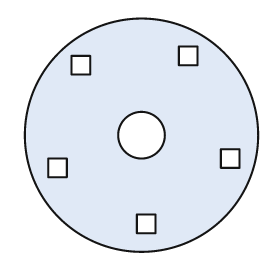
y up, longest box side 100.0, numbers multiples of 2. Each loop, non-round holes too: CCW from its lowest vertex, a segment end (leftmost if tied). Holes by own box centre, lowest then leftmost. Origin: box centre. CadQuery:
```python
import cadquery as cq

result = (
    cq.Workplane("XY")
    .moveTo(0.0, 0.0)
    .circle(50.0)
    .moveTo(-2.0, -42.0)
    .lineTo(6.0, -42.0)
    .lineTo(6.0, -34.0)
    .lineTo(-2.0, -34.0)
    .close()
    .moveTo(-40.0, -18.0)
    .lineTo(-32.0, -18.0)
    .lineTo(-32.0, -10.0)
    .lineTo(-40.0, -10.0)
    .close()
    .moveTo(34.0, -14.0)
    .lineTo(42.0, -14.0)
    .lineTo(42.0, -6.0)
    .lineTo(34.0, -6.0)
    .close()
    .moveTo(0.0, 0.0)
    .circle(10.0)
    .moveTo(-30.0, 26.0)
    .lineTo(-22.0, 26.0)
    .lineTo(-22.0, 34.0)
    .lineTo(-30.0, 34.0)
    .close()
    .moveTo(16.0, 30.0)
    .lineTo(24.0, 30.0)
    .lineTo(24.0, 38.0)
    .lineTo(16.0, 38.0)
    .close()
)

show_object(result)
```